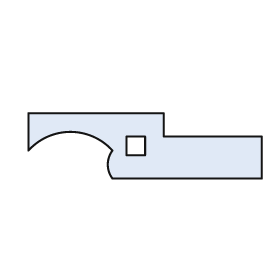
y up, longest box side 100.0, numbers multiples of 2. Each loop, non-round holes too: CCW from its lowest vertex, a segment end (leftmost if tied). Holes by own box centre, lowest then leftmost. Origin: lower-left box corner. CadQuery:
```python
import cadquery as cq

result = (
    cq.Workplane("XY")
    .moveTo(36.0, 0.0)
    .lineTo(100.0, 0.0)
    .lineTo(100.0, 18.0)
    .lineTo(58.0, 18.0)
    .lineTo(58.0, 28.0)
    .lineTo(0.0, 28.0)
    .lineTo(0.0, 12.0)
    .threePointArc((18.0, 20.0), (36.0, 12.0))
    .threePointArc((34.0, 6.0), (36.0, 0.0))
    .close()
    .moveTo(42.0, 10.0)
    .lineTo(50.0, 10.0)
    .lineTo(50.0, 18.0)
    .lineTo(42.0, 18.0)
    .close()
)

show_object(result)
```